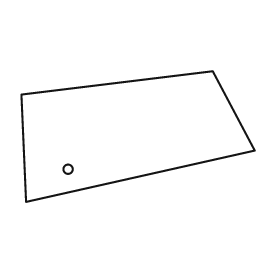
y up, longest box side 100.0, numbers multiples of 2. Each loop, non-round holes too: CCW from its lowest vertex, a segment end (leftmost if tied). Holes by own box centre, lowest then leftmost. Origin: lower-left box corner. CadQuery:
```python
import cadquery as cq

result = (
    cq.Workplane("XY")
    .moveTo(2.0, 0.0)
    .lineTo(100.0, 22.0)
    .lineTo(82.0, 56.0)
    .lineTo(0.0, 46.0)
    .close()
    .moveTo(20.0, 14.0)
    .circle(2.0)
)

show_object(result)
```